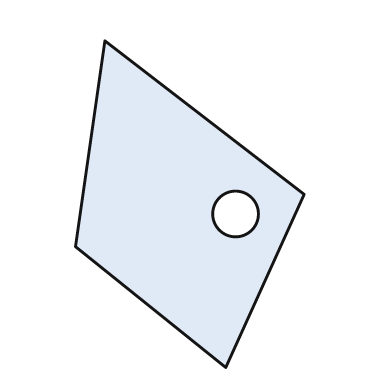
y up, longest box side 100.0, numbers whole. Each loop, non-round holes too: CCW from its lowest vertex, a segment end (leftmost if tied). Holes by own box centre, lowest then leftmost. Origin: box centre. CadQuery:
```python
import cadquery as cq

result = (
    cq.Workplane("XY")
    .moveTo(11.0, -50.0)
    .lineTo(35.0, 3.0)
    .lineTo(-26.0, 50.0)
    .lineTo(-35.0, -13.0)
    .close()
    .moveTo(14.0, -3.0)
    .circle(7.0)
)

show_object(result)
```